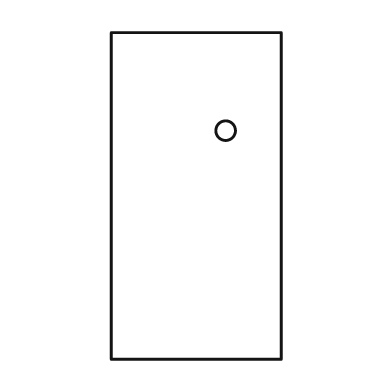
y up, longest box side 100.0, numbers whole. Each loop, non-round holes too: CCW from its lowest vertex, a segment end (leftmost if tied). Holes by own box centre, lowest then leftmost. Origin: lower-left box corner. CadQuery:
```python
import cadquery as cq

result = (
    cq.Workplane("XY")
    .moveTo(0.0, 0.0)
    .lineTo(52.0, 0.0)
    .lineTo(52.0, 100.0)
    .lineTo(0.0, 100.0)
    .close()
    .moveTo(35.0, 70.0)
    .circle(3.0)
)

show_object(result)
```